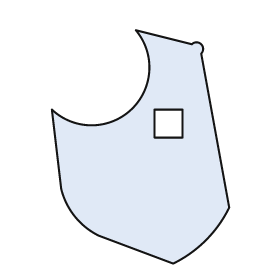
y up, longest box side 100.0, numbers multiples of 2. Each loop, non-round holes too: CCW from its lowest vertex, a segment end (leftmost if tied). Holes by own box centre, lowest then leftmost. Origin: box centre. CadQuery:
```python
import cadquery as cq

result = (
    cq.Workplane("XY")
    .moveTo(14.0, -50.0)
    .threePointArc((28.0, -40.0), (38.0, -26.0))
    .lineTo(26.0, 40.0)
    .threePointArc((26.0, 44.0), (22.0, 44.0))
    .lineTo(-2.0, 50.0)
    .threePointArc((-4.0, 16.0), (-38.0, 16.0))
    .lineTo(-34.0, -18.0)
    .threePointArc((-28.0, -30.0), (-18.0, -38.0))
    .close()
    .moveTo(6.0, 4.0)
    .lineTo(18.0, 4.0)
    .lineTo(18.0, 16.0)
    .lineTo(6.0, 16.0)
    .close()
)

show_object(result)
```